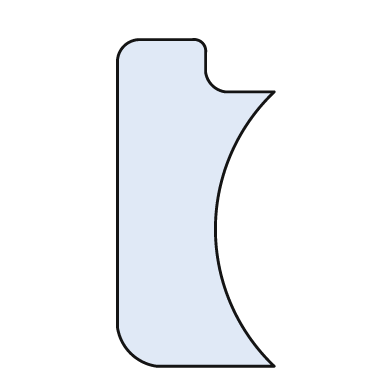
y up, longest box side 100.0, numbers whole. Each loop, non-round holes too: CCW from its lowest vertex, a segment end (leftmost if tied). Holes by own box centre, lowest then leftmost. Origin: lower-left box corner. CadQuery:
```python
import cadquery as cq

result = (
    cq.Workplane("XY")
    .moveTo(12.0, 0.0)
    .lineTo(48.0, 0.0)
    .threePointArc((30.0, 42.0), (48.0, 84.0))
    .lineTo(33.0, 84.0)
    .threePointArc((29.0, 86.0), (27.0, 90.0))
    .lineTo(27.0, 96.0)
    .threePointArc((26.0, 99.0), (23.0, 100.0))
    .lineTo(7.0, 100.0)
    .threePointArc((2.0, 98.0), (0.0, 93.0))
    .lineTo(0.0, 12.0)
    .threePointArc((4.0, 4.0), (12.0, 0.0))
    .close()
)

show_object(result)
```